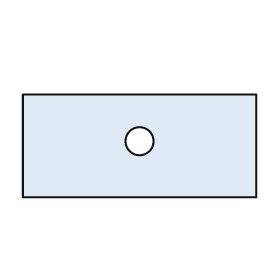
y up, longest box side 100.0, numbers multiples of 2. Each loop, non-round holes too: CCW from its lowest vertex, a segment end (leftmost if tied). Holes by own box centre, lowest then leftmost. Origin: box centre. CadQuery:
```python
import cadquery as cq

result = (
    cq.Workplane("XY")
    .moveTo(-50.0, -22.0)
    .lineTo(50.0, -22.0)
    .lineTo(50.0, 22.0)
    .lineTo(-50.0, 22.0)
    .close()
    .moveTo(0.0, 2.0)
    .circle(6.0)
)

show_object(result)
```